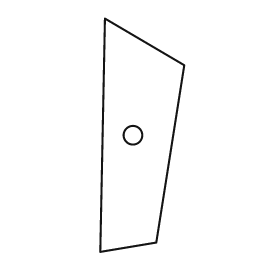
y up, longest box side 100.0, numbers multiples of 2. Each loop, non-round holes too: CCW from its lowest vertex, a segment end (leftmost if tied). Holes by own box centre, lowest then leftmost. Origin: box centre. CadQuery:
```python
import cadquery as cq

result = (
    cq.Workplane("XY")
    .moveTo(-18.0, -50.0)
    .lineTo(6.0, -46.0)
    .lineTo(18.0, 30.0)
    .lineTo(-16.0, 50.0)
    .close()
    .moveTo(-4.0, 0.0)
    .circle(4.0)
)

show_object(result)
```